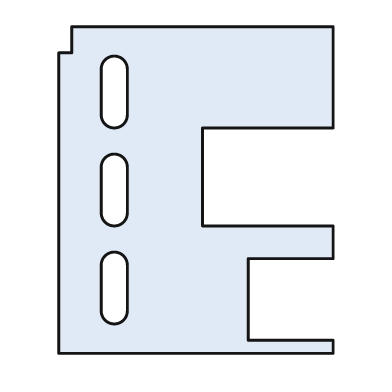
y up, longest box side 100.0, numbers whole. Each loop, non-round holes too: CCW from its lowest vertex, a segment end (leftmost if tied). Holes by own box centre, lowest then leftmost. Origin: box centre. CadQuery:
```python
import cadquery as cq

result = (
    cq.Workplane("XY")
    .moveTo(-42.0, -50.0)
    .lineTo(42.0, -50.0)
    .lineTo(42.0, -46.0)
    .lineTo(16.0, -46.0)
    .lineTo(16.0, -21.0)
    .lineTo(42.0, -21.0)
    .lineTo(42.0, -11.0)
    .lineTo(2.0, -11.0)
    .lineTo(2.0, 19.0)
    .lineTo(42.0, 19.0)
    .lineTo(42.0, 50.0)
    .lineTo(-38.0, 50.0)
    .lineTo(-38.0, 42.0)
    .lineTo(-42.0, 42.0)
    .close()
    .moveTo(-29.0, -37.0)
    .threePointArc((-25.0, -41.0), (-21.0, -37.0))
    .lineTo(-21.0, -23.0)
    .threePointArc((-25.0, -19.0), (-29.0, -23.0))
    .close()
    .moveTo(-29.0, -7.0)
    .threePointArc((-25.0, -11.0), (-21.0, -7.0))
    .lineTo(-21.0, 7.0)
    .threePointArc((-25.0, 11.0), (-29.0, 7.0))
    .close()
    .moveTo(-29.0, 23.0)
    .threePointArc((-25.0, 19.0), (-21.0, 23.0))
    .lineTo(-21.0, 37.0)
    .threePointArc((-25.0, 41.0), (-29.0, 37.0))
    .close()
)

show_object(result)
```